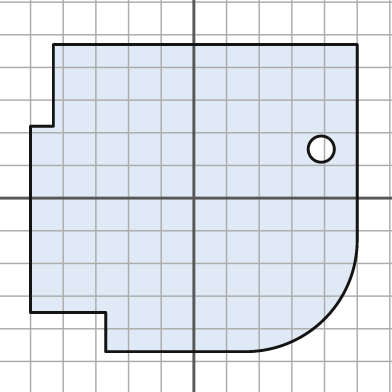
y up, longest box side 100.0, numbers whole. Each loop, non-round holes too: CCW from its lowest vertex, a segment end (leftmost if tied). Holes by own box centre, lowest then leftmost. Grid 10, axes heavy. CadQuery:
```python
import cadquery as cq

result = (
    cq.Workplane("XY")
    .moveTo(-27.0, -47.0)
    .lineTo(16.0, -47.0)
    .threePointArc((40.0, -37.0), (50.0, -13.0))
    .lineTo(50.0, 47.0)
    .lineTo(-43.0, 47.0)
    .lineTo(-43.0, 22.0)
    .lineTo(-50.0, 22.0)
    .lineTo(-50.0, -35.0)
    .lineTo(-27.0, -35.0)
    .close()
    .moveTo(39.0, 15.0)
    .circle(4.0)
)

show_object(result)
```